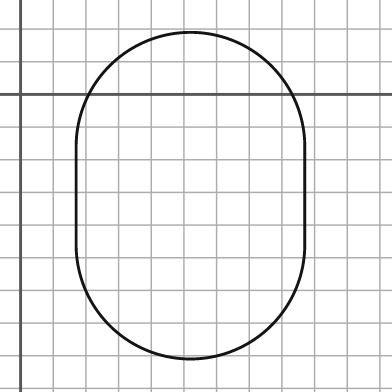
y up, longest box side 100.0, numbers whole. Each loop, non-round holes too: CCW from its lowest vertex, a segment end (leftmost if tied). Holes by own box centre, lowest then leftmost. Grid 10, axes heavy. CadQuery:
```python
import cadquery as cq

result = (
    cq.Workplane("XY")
    .moveTo(17.0, -46.0)
    .threePointArc((52.0, -81.0), (87.0, -46.0))
    .lineTo(87.0, -16.0)
    .threePointArc((52.0, 19.0), (17.0, -16.0))
    .close()
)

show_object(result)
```